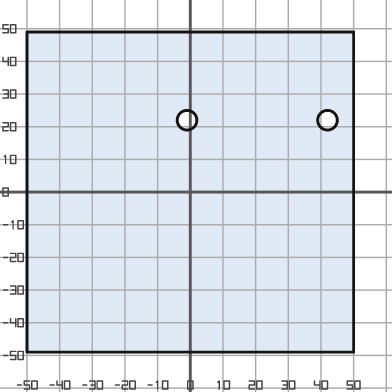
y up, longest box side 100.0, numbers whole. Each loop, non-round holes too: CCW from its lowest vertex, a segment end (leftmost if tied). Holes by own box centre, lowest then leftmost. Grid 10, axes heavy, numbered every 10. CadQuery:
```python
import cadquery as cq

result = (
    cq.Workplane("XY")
    .moveTo(-50.0, -49.0)
    .lineTo(50.0, -49.0)
    .lineTo(50.0, 49.0)
    .lineTo(-50.0, 49.0)
    .close()
    .moveTo(-1.0, 22.0)
    .circle(3.0)
    .moveTo(42.0, 22.0)
    .circle(3.0)
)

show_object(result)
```